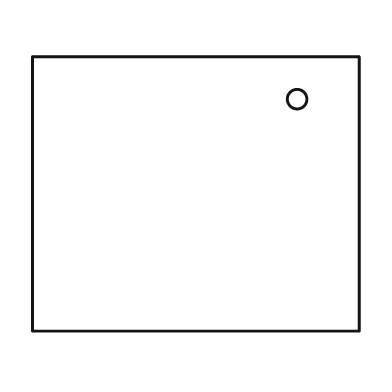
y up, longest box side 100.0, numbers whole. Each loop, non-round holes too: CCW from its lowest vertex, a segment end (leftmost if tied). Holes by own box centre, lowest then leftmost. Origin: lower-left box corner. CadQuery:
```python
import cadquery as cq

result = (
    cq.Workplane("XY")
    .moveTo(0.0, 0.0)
    .lineTo(100.0, 0.0)
    .lineTo(100.0, 84.0)
    .lineTo(0.0, 84.0)
    .close()
    .moveTo(81.0, 71.0)
    .circle(3.0)
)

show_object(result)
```